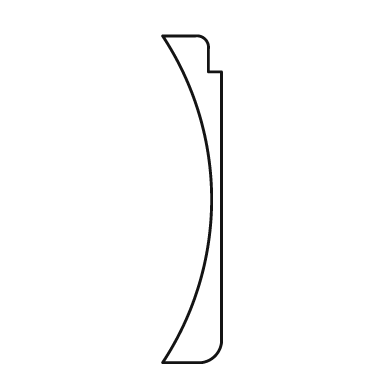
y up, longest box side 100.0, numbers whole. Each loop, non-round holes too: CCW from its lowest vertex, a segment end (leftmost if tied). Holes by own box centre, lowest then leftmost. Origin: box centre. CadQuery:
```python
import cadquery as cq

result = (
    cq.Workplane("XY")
    .moveTo(-9.0, -50.0)
    .lineTo(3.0, -50.0)
    .threePointArc((7.0, -48.0), (9.0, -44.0))
    .lineTo(9.0, 39.0)
    .lineTo(5.0, 39.0)
    .lineTo(5.0, 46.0)
    .threePointArc((4.0, 49.0), (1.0, 50.0))
    .lineTo(-9.0, 50.0)
    .threePointArc((6.0, 0.0), (-9.0, -50.0))
    .close()
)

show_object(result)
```